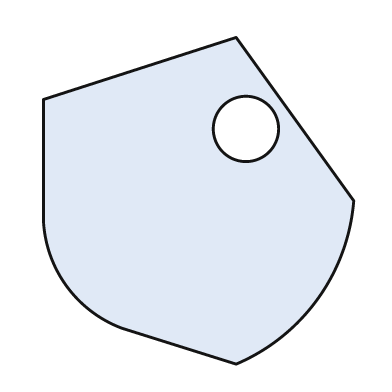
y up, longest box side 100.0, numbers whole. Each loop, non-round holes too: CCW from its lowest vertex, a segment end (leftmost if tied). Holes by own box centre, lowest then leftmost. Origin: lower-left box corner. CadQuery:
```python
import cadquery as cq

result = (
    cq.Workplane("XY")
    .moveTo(59.0, 0.0)
    .threePointArc((84.0, 20.0), (95.0, 50.0))
    .lineTo(59.0, 100.0)
    .lineTo(0.0, 81.0)
    .lineTo(0.0, 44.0)
    .threePointArc((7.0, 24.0), (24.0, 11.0))
    .close()
    .moveTo(62.0, 72.0)
    .circle(10.0)
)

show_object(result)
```